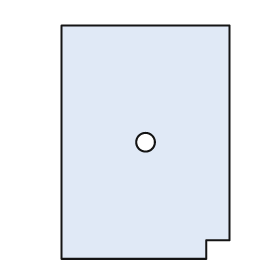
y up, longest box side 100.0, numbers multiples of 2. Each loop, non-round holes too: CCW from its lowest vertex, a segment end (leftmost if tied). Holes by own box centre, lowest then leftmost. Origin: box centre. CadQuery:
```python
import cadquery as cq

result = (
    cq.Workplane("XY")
    .moveTo(-36.0, -50.0)
    .lineTo(26.0, -50.0)
    .lineTo(26.0, -42.0)
    .lineTo(36.0, -42.0)
    .lineTo(36.0, 50.0)
    .lineTo(-36.0, 50.0)
    .close()
    .moveTo(0.0, 0.0)
    .circle(4.0)
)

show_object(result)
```